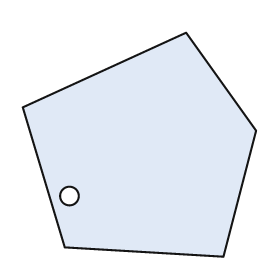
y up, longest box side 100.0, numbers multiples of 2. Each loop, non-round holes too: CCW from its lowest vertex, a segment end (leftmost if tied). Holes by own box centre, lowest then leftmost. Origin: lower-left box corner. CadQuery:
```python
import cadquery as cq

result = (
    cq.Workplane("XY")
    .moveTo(86.0, 0.0)
    .lineTo(100.0, 54.0)
    .lineTo(70.0, 96.0)
    .lineTo(0.0, 64.0)
    .lineTo(18.0, 4.0)
    .close()
    .moveTo(20.0, 26.0)
    .circle(4.0)
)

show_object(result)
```